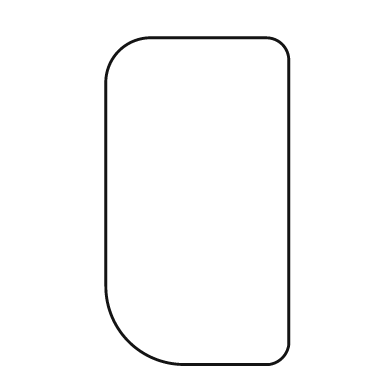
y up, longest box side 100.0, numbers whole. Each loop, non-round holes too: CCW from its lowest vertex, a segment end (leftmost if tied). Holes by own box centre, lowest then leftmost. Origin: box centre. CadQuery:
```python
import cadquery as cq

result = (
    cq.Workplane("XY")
    .moveTo(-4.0, -50.0)
    .lineTo(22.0, -50.0)
    .threePointArc((26.0, -48.0), (28.0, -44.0))
    .lineTo(28.0, 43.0)
    .threePointArc((26.0, 48.0), (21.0, 50.0))
    .lineTo(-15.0, 50.0)
    .threePointArc((-24.0, 46.0), (-28.0, 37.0))
    .lineTo(-28.0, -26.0)
    .threePointArc((-21.0, -43.0), (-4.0, -50.0))
    .close()
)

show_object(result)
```